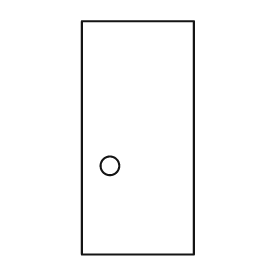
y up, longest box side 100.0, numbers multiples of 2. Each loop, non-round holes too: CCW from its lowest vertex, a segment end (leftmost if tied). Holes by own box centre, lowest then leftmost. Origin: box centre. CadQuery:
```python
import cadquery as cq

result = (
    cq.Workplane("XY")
    .moveTo(-24.0, -50.0)
    .lineTo(24.0, -50.0)
    .lineTo(24.0, 50.0)
    .lineTo(-24.0, 50.0)
    .close()
    .moveTo(-12.0, -12.0)
    .circle(4.0)
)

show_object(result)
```